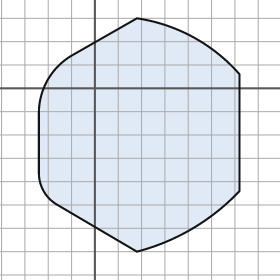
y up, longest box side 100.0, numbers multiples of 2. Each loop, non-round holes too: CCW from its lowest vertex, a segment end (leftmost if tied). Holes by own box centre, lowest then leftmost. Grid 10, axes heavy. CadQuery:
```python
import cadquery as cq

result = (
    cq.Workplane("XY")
    .moveTo(18.0, -70.0)
    .threePointArc((42.0, -60.0), (62.0, -44.0))
    .lineTo(62.0, 6.0)
    .threePointArc((42.0, 22.0), (18.0, 30.0))
    .lineTo(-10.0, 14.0)
    .threePointArc((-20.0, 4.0), (-24.0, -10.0))
    .lineTo(-24.0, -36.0)
    .threePointArc((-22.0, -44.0), (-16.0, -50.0))
    .close()
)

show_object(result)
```